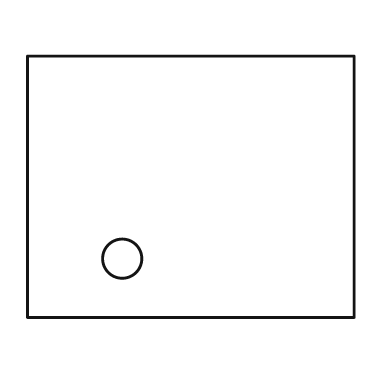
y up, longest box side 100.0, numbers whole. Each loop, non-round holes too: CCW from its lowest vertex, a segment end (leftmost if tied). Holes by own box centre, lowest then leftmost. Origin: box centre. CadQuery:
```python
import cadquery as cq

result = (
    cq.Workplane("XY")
    .moveTo(-50.0, -40.0)
    .lineTo(50.0, -40.0)
    .lineTo(50.0, 40.0)
    .lineTo(-50.0, 40.0)
    .close()
    .moveTo(-21.0, -22.0)
    .circle(6.0)
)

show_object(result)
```